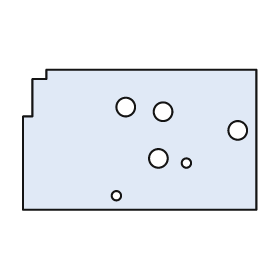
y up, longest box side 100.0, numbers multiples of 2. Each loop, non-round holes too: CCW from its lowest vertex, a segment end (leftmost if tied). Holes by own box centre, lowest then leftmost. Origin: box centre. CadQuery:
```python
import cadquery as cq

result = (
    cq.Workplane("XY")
    .moveTo(-50.0, -30.0)
    .lineTo(50.0, -30.0)
    .lineTo(50.0, 30.0)
    .lineTo(-40.0, 30.0)
    .lineTo(-40.0, 26.0)
    .lineTo(-46.0, 26.0)
    .lineTo(-46.0, 10.0)
    .lineTo(-50.0, 10.0)
    .close()
    .moveTo(-10.0, -24.0)
    .circle(2.0)
    .moveTo(20.0, -10.0)
    .circle(2.0)
    .moveTo(8.0, -8.0)
    .circle(4.0)
    .moveTo(42.0, 4.0)
    .circle(4.0)
    .moveTo(10.0, 12.0)
    .circle(4.0)
    .moveTo(-6.0, 14.0)
    .circle(4.0)
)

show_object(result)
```